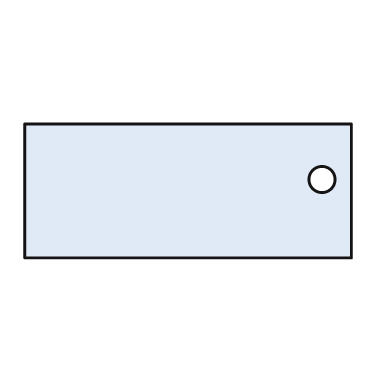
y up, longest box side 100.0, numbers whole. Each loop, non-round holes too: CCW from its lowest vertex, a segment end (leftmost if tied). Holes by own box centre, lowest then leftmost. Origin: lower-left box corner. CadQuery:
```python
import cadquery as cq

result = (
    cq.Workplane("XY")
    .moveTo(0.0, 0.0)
    .lineTo(100.0, 0.0)
    .lineTo(100.0, 41.0)
    .lineTo(0.0, 41.0)
    .close()
    .moveTo(91.0, 24.0)
    .circle(4.0)
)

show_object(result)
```